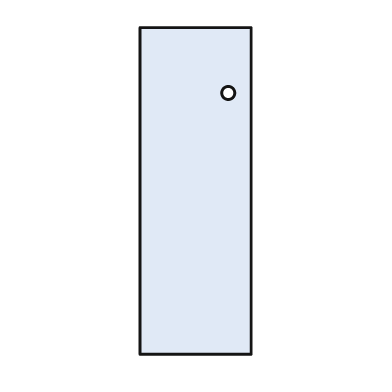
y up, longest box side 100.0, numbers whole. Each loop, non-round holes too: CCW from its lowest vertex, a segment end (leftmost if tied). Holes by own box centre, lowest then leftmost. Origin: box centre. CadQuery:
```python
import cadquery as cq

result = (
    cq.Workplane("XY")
    .moveTo(-17.0, -50.0)
    .lineTo(17.0, -50.0)
    .lineTo(17.0, 50.0)
    .lineTo(-17.0, 50.0)
    .close()
    .moveTo(10.0, 30.0)
    .circle(2.0)
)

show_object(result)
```